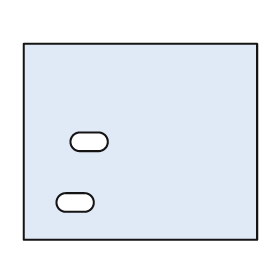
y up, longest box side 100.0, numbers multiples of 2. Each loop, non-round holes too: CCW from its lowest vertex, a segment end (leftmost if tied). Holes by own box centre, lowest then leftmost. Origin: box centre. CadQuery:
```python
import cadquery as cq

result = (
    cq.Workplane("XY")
    .moveTo(-50.0, -42.0)
    .lineTo(50.0, -42.0)
    .lineTo(50.0, 42.0)
    .lineTo(-50.0, 42.0)
    .close()
    .moveTo(-32.0, -30.0)
    .lineTo(-24.0, -30.0)
    .threePointArc((-20.0, -26.0), (-24.0, -22.0))
    .lineTo(-32.0, -22.0)
    .threePointArc((-36.0, -26.0), (-32.0, -30.0))
    .close()
    .moveTo(-26.0, -4.0)
    .lineTo(-18.0, -4.0)
    .threePointArc((-14.0, 0.0), (-18.0, 4.0))
    .lineTo(-26.0, 4.0)
    .threePointArc((-30.0, 0.0), (-26.0, -4.0))
    .close()
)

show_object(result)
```